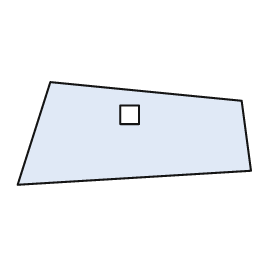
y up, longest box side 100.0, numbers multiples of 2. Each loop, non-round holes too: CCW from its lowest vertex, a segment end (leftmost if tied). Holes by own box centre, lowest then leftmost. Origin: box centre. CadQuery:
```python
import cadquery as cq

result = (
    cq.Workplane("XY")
    .moveTo(-50.0, -22.0)
    .lineTo(50.0, -16.0)
    .lineTo(46.0, 14.0)
    .lineTo(-36.0, 22.0)
    .close()
    .moveTo(-6.0, 4.0)
    .lineTo(2.0, 4.0)
    .lineTo(2.0, 12.0)
    .lineTo(-6.0, 12.0)
    .close()
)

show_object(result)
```